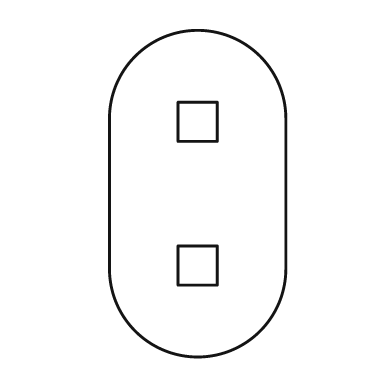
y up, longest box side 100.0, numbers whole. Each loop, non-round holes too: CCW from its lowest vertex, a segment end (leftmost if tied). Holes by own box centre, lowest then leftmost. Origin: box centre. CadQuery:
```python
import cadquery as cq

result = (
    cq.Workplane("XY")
    .moveTo(-27.0, -23.0)
    .threePointArc((0.0, -50.0), (27.0, -23.0))
    .lineTo(27.0, 23.0)
    .threePointArc((0.0, 50.0), (-27.0, 23.0))
    .close()
    .moveTo(-6.0, -28.0)
    .lineTo(6.0, -28.0)
    .lineTo(6.0, -16.0)
    .lineTo(-6.0, -16.0)
    .close()
    .moveTo(-6.0, 16.0)
    .lineTo(6.0, 16.0)
    .lineTo(6.0, 28.0)
    .lineTo(-6.0, 28.0)
    .close()
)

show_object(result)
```